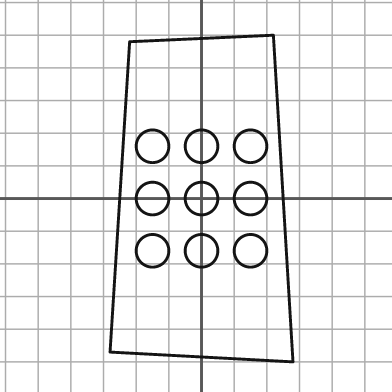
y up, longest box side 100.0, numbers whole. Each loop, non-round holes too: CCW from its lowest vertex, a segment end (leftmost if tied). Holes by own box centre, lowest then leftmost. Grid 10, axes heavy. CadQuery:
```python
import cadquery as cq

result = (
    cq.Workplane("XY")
    .moveTo(28.0, -50.0)
    .lineTo(22.0, 50.0)
    .lineTo(-22.0, 48.0)
    .lineTo(-28.0, -47.0)
    .close()
    .moveTo(-15.0, -16.0)
    .circle(5.0)
    .moveTo(0.0, -16.0)
    .circle(5.0)
    .moveTo(15.0, -16.0)
    .circle(5.0)
    .moveTo(-15.0, 0.0)
    .circle(5.0)
    .moveTo(0.0, 0.0)
    .circle(5.0)
    .moveTo(15.0, 0.0)
    .circle(5.0)
    .moveTo(-15.0, 16.0)
    .circle(5.0)
    .moveTo(0.0, 16.0)
    .circle(5.0)
    .moveTo(15.0, 16.0)
    .circle(5.0)
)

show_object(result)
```